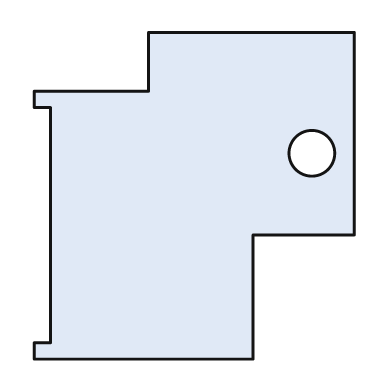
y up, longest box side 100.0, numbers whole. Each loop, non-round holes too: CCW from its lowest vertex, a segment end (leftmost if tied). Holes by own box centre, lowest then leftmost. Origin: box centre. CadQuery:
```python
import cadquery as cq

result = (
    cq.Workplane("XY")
    .moveTo(-49.0, -50.0)
    .lineTo(18.0, -50.0)
    .lineTo(18.0, -12.0)
    .lineTo(49.0, -12.0)
    .lineTo(49.0, 50.0)
    .lineTo(-14.0, 50.0)
    .lineTo(-14.0, 32.0)
    .lineTo(-49.0, 32.0)
    .lineTo(-49.0, 27.0)
    .lineTo(-44.0, 27.0)
    .lineTo(-44.0, -45.0)
    .lineTo(-49.0, -45.0)
    .close()
    .moveTo(36.0, 13.0)
    .circle(7.0)
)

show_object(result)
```